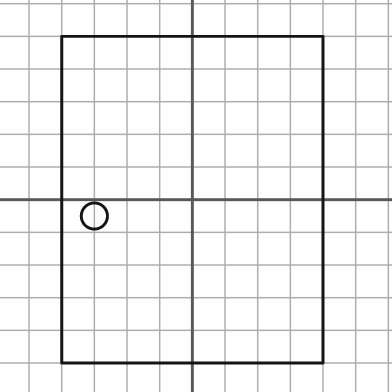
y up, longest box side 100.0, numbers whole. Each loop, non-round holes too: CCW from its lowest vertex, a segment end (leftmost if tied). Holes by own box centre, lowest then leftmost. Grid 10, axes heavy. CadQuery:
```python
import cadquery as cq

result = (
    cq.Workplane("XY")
    .moveTo(-40.0, -50.0)
    .lineTo(40.0, -50.0)
    .lineTo(40.0, 50.0)
    .lineTo(-40.0, 50.0)
    .close()
    .moveTo(-30.0, -5.0)
    .circle(4.0)
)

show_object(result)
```